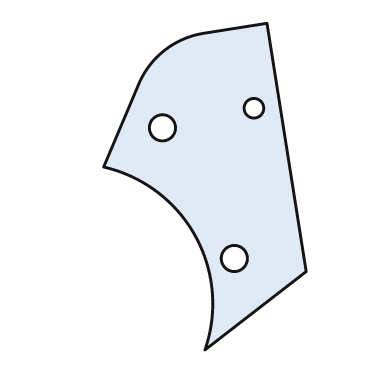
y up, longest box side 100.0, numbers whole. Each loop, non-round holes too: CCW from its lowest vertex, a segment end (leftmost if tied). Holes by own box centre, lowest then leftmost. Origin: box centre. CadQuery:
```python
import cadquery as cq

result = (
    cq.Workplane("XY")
    .moveTo(0.0, -50.0)
    .lineTo(31.0, -26.0)
    .lineTo(19.0, 50.0)
    .lineTo(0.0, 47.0)
    .threePointArc((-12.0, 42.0), (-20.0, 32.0))
    .lineTo(-31.0, 6.0)
    .threePointArc((-3.0, -15.0), (0.0, -50.0))
    .close()
    .moveTo(9.0, -22.0)
    .circle(4.0)
    .moveTo(-13.0, 18.0)
    .circle(4.0)
    .moveTo(15.0, 24.0)
    .circle(3.0)
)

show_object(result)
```